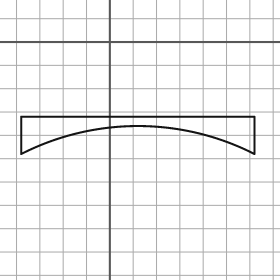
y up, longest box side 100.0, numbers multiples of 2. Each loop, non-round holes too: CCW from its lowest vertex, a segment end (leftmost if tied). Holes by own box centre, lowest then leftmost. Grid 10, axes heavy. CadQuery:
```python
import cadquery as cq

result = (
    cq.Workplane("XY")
    .moveTo(-38.0, -48.0)
    .threePointArc((12.0, -36.0), (62.0, -48.0))
    .lineTo(62.0, -32.0)
    .lineTo(-38.0, -32.0)
    .close()
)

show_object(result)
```